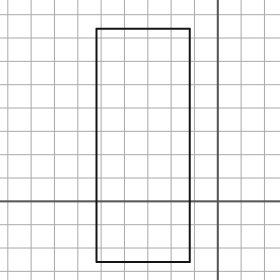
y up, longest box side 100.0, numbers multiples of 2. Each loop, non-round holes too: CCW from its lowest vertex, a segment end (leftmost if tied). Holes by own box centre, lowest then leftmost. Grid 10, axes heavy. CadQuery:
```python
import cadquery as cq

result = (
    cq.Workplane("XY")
    .moveTo(-52.0, -26.0)
    .lineTo(-12.0, -26.0)
    .lineTo(-12.0, 74.0)
    .lineTo(-52.0, 74.0)
    .close()
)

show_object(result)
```